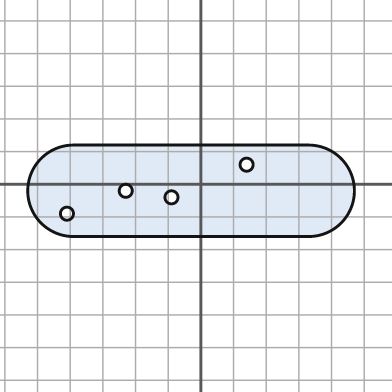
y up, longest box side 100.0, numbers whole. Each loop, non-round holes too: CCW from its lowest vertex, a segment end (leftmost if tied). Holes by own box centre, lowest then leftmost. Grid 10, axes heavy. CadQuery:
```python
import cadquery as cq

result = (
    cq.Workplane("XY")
    .moveTo(-39.0, -16.0)
    .lineTo(33.0, -16.0)
    .threePointArc((47.0, -2.0), (33.0, 12.0))
    .lineTo(-39.0, 12.0)
    .threePointArc((-53.0, -2.0), (-39.0, -16.0))
    .close()
    .moveTo(-41.0, -9.0)
    .circle(2.0)
    .moveTo(-9.0, -4.0)
    .circle(2.0)
    .moveTo(-23.0, -2.0)
    .circle(2.0)
    .moveTo(14.0, 6.0)
    .circle(2.0)
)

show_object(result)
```